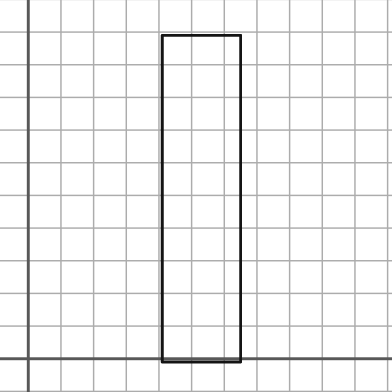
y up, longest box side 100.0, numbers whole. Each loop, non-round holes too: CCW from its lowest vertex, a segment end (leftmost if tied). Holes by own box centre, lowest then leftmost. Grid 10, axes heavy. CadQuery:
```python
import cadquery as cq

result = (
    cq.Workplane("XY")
    .moveTo(41.0, -1.0)
    .lineTo(65.0, -1.0)
    .lineTo(65.0, 99.0)
    .lineTo(41.0, 99.0)
    .close()
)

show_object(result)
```